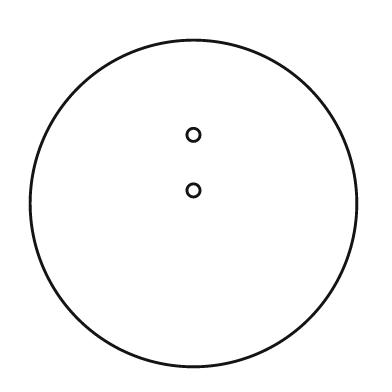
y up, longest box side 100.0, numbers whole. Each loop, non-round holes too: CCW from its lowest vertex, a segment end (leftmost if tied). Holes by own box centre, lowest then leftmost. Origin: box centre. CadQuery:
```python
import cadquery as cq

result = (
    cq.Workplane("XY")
    .moveTo(0.0, 0.0)
    .circle(50.0)
    .moveTo(0.0, 4.0)
    .circle(2.0)
    .moveTo(0.0, 21.0)
    .circle(2.0)
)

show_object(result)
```